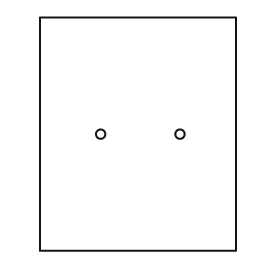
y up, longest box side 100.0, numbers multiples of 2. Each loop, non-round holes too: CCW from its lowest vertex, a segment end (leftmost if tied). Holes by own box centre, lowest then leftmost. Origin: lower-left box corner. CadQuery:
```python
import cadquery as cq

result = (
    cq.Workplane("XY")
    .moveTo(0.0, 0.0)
    .lineTo(84.0, 0.0)
    .lineTo(84.0, 100.0)
    .lineTo(0.0, 100.0)
    .close()
    .moveTo(26.0, 50.0)
    .circle(2.0)
    .moveTo(60.0, 50.0)
    .circle(2.0)
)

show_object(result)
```